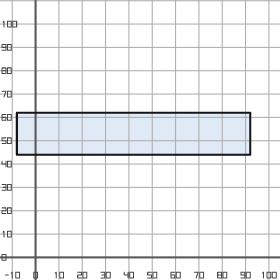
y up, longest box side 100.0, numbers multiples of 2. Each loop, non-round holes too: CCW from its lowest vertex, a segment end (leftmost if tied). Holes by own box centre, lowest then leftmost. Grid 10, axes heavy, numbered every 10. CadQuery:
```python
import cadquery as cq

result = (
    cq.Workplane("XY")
    .moveTo(-8.0, 44.0)
    .lineTo(92.0, 44.0)
    .lineTo(92.0, 62.0)
    .lineTo(-8.0, 62.0)
    .close()
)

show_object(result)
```